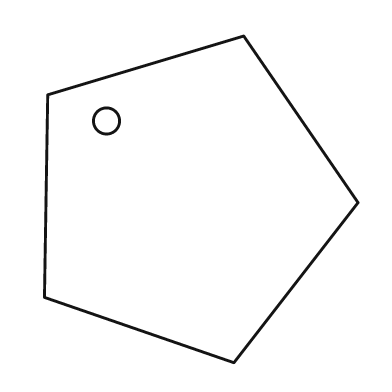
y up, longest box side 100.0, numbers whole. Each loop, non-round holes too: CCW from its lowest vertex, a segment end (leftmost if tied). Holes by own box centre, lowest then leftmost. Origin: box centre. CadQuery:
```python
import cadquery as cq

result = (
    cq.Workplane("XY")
    .moveTo(10.0, -50.0)
    .lineTo(48.0, -1.0)
    .lineTo(13.0, 50.0)
    .lineTo(-47.0, 32.0)
    .lineTo(-48.0, -30.0)
    .close()
    .moveTo(-29.0, 24.0)
    .circle(4.0)
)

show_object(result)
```